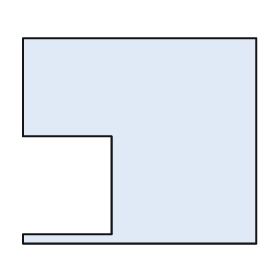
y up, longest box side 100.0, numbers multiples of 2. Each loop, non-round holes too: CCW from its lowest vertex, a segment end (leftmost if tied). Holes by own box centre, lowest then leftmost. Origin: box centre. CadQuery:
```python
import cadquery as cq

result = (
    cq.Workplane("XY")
    .moveTo(-50.0, -44.0)
    .lineTo(50.0, -44.0)
    .lineTo(50.0, 44.0)
    .lineTo(-50.0, 44.0)
    .lineTo(-50.0, 2.0)
    .lineTo(-12.0, 2.0)
    .lineTo(-12.0, -40.0)
    .lineTo(-50.0, -40.0)
    .close()
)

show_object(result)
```